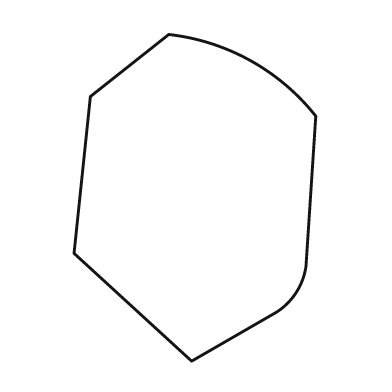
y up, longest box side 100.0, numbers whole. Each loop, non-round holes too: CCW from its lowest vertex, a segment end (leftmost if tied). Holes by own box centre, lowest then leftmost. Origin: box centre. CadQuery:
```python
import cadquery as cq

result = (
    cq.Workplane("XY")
    .moveTo(-1.0, -50.0)
    .lineTo(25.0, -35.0)
    .threePointArc((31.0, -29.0), (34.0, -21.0))
    .lineTo(37.0, 25.0)
    .threePointArc((17.0, 42.0), (-8.0, 50.0))
    .lineTo(-32.0, 31.0)
    .lineTo(-37.0, -17.0)
    .close()
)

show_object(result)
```